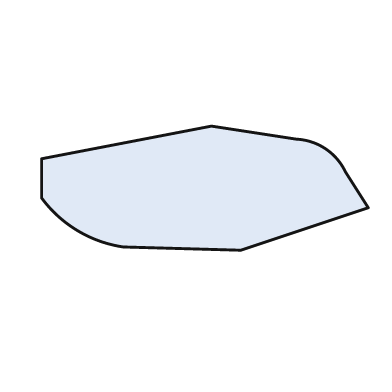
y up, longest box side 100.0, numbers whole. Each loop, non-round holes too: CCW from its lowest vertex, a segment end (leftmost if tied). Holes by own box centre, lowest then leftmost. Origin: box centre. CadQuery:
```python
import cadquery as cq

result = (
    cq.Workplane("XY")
    .moveTo(11.0, -19.0)
    .lineTo(50.0, -6.0)
    .lineTo(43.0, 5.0)
    .threePointArc((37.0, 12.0), (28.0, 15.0))
    .lineTo(2.0, 19.0)
    .lineTo(-50.0, 9.0)
    .lineTo(-50.0, -3.0)
    .threePointArc((-39.0, -13.0), (-25.0, -18.0))
    .close()
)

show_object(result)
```